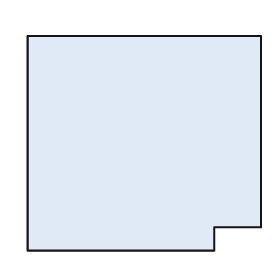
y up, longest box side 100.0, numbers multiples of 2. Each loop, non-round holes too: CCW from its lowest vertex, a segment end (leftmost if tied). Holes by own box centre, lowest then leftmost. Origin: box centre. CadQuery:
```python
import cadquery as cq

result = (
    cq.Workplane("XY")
    .moveTo(-50.0, -46.0)
    .lineTo(30.0, -46.0)
    .lineTo(30.0, -36.0)
    .lineTo(50.0, -36.0)
    .lineTo(50.0, 46.0)
    .lineTo(-50.0, 46.0)
    .close()
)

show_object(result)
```